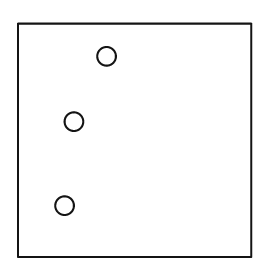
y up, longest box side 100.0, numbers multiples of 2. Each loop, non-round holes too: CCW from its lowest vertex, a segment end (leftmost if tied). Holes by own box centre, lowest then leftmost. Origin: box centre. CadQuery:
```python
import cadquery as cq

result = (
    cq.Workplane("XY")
    .moveTo(-50.0, -50.0)
    .lineTo(50.0, -50.0)
    .lineTo(50.0, 50.0)
    .lineTo(-50.0, 50.0)
    .close()
    .moveTo(-30.0, -28.0)
    .circle(4.0)
    .moveTo(-26.0, 8.0)
    .circle(4.0)
    .moveTo(-12.0, 36.0)
    .circle(4.0)
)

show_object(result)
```